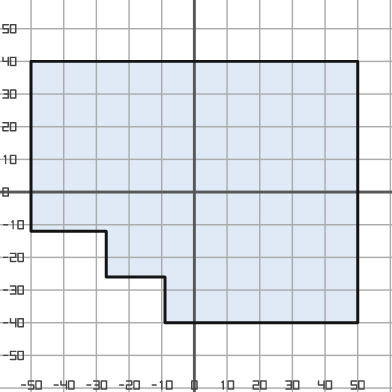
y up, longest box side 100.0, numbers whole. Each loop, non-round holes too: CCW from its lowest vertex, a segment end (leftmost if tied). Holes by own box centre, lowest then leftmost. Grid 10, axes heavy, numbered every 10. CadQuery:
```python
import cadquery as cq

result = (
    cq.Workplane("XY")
    .moveTo(-9.0, -40.0)
    .lineTo(50.0, -40.0)
    .lineTo(50.0, 40.0)
    .lineTo(-50.0, 40.0)
    .lineTo(-50.0, -12.0)
    .lineTo(-27.0, -12.0)
    .lineTo(-27.0, -26.0)
    .lineTo(-9.0, -26.0)
    .close()
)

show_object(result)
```